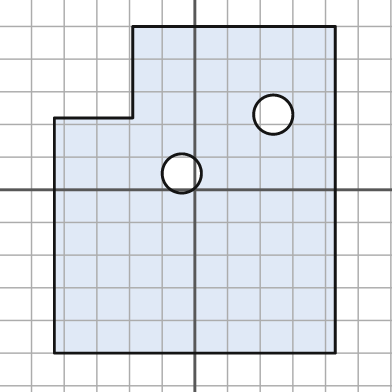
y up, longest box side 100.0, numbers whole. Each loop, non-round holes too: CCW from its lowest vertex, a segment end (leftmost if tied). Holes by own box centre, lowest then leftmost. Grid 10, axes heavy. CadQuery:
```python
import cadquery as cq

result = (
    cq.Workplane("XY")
    .moveTo(-43.0, -50.0)
    .lineTo(43.0, -50.0)
    .lineTo(43.0, 50.0)
    .lineTo(-19.0, 50.0)
    .lineTo(-19.0, 22.0)
    .lineTo(-43.0, 22.0)
    .close()
    .moveTo(-4.0, 5.0)
    .circle(6.0)
    .moveTo(24.0, 23.0)
    .circle(6.0)
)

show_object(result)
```